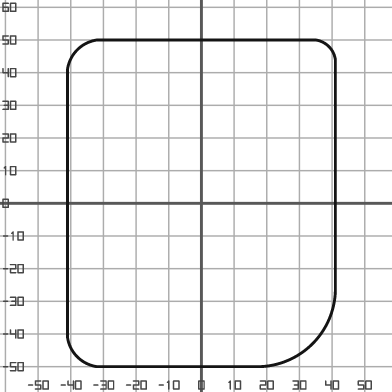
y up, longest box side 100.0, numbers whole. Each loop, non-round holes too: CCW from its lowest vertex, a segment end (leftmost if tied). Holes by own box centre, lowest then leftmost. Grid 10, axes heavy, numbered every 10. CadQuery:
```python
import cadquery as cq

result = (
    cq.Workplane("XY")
    .moveTo(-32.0, -50.0)
    .lineTo(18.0, -50.0)
    .threePointArc((34.0, -43.0), (41.0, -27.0))
    .lineTo(41.0, 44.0)
    .threePointArc((39.0, 48.0), (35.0, 50.0))
    .lineTo(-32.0, 50.0)
    .threePointArc((-38.0, 47.0), (-41.0, 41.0))
    .lineTo(-41.0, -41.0)
    .threePointArc((-38.0, -47.0), (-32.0, -50.0))
    .close()
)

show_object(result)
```